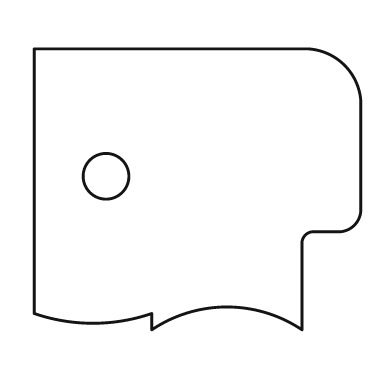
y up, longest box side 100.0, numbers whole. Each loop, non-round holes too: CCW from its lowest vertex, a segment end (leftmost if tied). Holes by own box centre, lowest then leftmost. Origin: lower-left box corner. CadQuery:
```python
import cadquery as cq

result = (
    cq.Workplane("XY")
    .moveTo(36.0, 0.0)
    .threePointArc((59.0, 7.0), (82.0, 0.0))
    .lineTo(82.0, 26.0)
    .threePointArc((83.0, 29.0), (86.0, 30.0))
    .lineTo(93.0, 30.0)
    .threePointArc((98.0, 32.0), (100.0, 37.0))
    .lineTo(100.0, 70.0)
    .threePointArc((95.0, 81.0), (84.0, 86.0))
    .lineTo(0.0, 86.0)
    .lineTo(0.0, 5.0)
    .threePointArc((18.0, 2.0), (36.0, 5.0))
    .close()
    .moveTo(22.0, 47.0)
    .circle(7.0)
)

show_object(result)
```